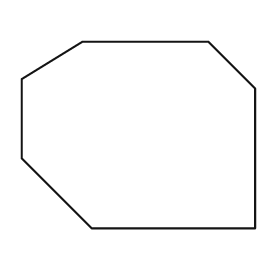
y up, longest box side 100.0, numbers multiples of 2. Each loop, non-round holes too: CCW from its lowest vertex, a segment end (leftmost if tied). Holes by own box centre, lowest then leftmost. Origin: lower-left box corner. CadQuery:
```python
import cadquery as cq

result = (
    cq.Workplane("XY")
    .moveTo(30.0, 0.0)
    .lineTo(100.0, 0.0)
    .lineTo(100.0, 60.0)
    .lineTo(80.0, 80.0)
    .lineTo(26.0, 80.0)
    .lineTo(0.0, 64.0)
    .lineTo(0.0, 30.0)
    .close()
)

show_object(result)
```